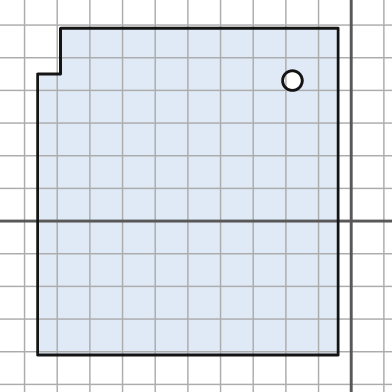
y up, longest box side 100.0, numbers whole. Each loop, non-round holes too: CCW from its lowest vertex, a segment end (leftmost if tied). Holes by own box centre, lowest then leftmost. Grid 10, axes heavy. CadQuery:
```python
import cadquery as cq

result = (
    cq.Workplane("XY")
    .moveTo(-96.0, -41.0)
    .lineTo(-4.0, -41.0)
    .lineTo(-4.0, 59.0)
    .lineTo(-89.0, 59.0)
    .lineTo(-89.0, 45.0)
    .lineTo(-96.0, 45.0)
    .close()
    .moveTo(-18.0, 43.0)
    .circle(3.0)
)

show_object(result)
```